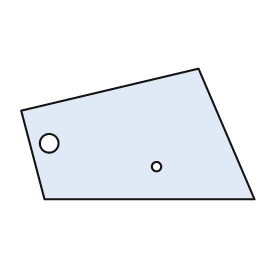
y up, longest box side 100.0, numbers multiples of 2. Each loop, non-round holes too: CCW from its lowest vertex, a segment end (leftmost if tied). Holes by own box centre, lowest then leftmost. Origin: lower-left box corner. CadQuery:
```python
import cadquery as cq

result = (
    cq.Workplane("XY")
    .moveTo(10.0, 0.0)
    .lineTo(100.0, 0.0)
    .lineTo(76.0, 56.0)
    .lineTo(0.0, 38.0)
    .close()
    .moveTo(58.0, 14.0)
    .circle(2.0)
    .moveTo(12.0, 24.0)
    .circle(4.0)
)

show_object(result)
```